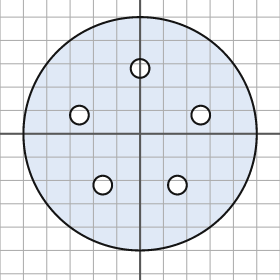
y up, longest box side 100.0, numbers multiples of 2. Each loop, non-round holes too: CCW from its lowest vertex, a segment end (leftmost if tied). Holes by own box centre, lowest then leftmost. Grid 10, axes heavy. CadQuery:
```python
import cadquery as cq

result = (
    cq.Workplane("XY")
    .moveTo(0.0, 0.0)
    .circle(50.0)
    .moveTo(-16.0, -22.0)
    .circle(4.0)
    .moveTo(16.0, -22.0)
    .circle(4.0)
    .moveTo(-26.0, 8.0)
    .circle(4.0)
    .moveTo(26.0, 8.0)
    .circle(4.0)
    .moveTo(0.0, 28.0)
    .circle(4.0)
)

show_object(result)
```